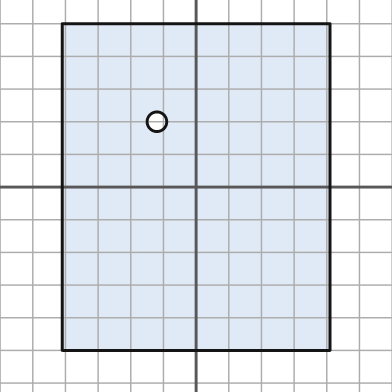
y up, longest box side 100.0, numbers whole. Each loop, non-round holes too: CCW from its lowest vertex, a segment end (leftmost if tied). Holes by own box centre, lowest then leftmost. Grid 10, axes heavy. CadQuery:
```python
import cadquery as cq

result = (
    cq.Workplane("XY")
    .moveTo(-41.0, -50.0)
    .lineTo(41.0, -50.0)
    .lineTo(41.0, 50.0)
    .lineTo(-41.0, 50.0)
    .close()
    .moveTo(-12.0, 20.0)
    .circle(3.0)
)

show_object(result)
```